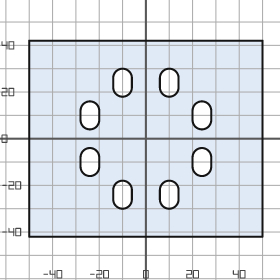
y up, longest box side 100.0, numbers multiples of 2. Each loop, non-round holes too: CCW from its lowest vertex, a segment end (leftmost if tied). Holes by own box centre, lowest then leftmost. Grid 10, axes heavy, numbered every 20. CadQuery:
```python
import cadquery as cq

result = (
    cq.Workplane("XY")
    .moveTo(-50.0, -42.0)
    .lineTo(50.0, -42.0)
    .lineTo(50.0, 42.0)
    .lineTo(-50.0, 42.0)
    .close()
    .moveTo(-14.0, -26.0)
    .threePointArc((-10.0, -30.0), (-6.0, -26.0))
    .lineTo(-6.0, -22.0)
    .threePointArc((-10.0, -18.0), (-14.0, -22.0))
    .close()
    .moveTo(6.0, -26.0)
    .threePointArc((10.0, -30.0), (14.0, -26.0))
    .lineTo(14.0, -22.0)
    .threePointArc((10.0, -18.0), (6.0, -22.0))
    .close()
    .moveTo(-28.0, -12.0)
    .threePointArc((-24.0, -16.0), (-20.0, -12.0))
    .lineTo(-20.0, -8.0)
    .threePointArc((-24.0, -4.0), (-28.0, -8.0))
    .close()
    .moveTo(20.0, -12.0)
    .threePointArc((24.0, -16.0), (28.0, -12.0))
    .lineTo(28.0, -8.0)
    .threePointArc((24.0, -4.0), (20.0, -8.0))
    .close()
    .moveTo(-28.0, 8.0)
    .threePointArc((-24.0, 4.0), (-20.0, 8.0))
    .lineTo(-20.0, 12.0)
    .threePointArc((-24.0, 16.0), (-28.0, 12.0))
    .close()
    .moveTo(20.0, 8.0)
    .threePointArc((24.0, 4.0), (28.0, 8.0))
    .lineTo(28.0, 12.0)
    .threePointArc((24.0, 16.0), (20.0, 12.0))
    .close()
    .moveTo(-14.0, 22.0)
    .threePointArc((-10.0, 18.0), (-6.0, 22.0))
    .lineTo(-6.0, 26.0)
    .threePointArc((-10.0, 30.0), (-14.0, 26.0))
    .close()
    .moveTo(6.0, 22.0)
    .threePointArc((10.0, 18.0), (14.0, 22.0))
    .lineTo(14.0, 26.0)
    .threePointArc((10.0, 30.0), (6.0, 26.0))
    .close()
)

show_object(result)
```